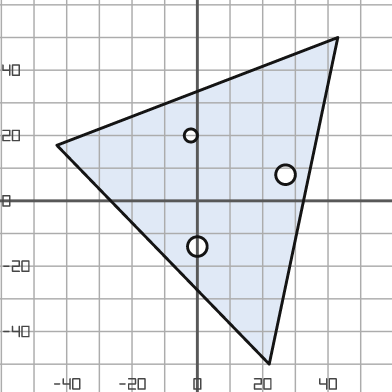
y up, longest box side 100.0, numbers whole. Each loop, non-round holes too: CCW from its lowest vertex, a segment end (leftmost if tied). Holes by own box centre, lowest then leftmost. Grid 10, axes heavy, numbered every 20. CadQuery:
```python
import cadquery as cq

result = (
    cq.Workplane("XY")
    .moveTo(22.0, -50.0)
    .lineTo(43.0, 50.0)
    .lineTo(-43.0, 17.0)
    .close()
    .moveTo(0.0, -14.0)
    .circle(3.0)
    .moveTo(27.0, 8.0)
    .circle(3.0)
    .moveTo(-2.0, 20.0)
    .circle(2.0)
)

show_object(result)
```